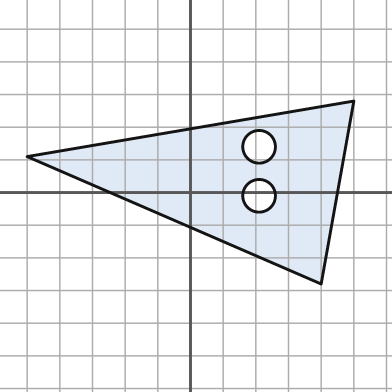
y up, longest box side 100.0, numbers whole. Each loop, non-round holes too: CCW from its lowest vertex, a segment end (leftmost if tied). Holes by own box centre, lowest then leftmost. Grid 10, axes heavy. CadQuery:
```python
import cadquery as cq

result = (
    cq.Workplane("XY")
    .moveTo(40.0, -28.0)
    .lineTo(50.0, 28.0)
    .lineTo(-50.0, 11.0)
    .close()
    .moveTo(21.0, -1.0)
    .circle(5.0)
    .moveTo(21.0, 14.0)
    .circle(5.0)
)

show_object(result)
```